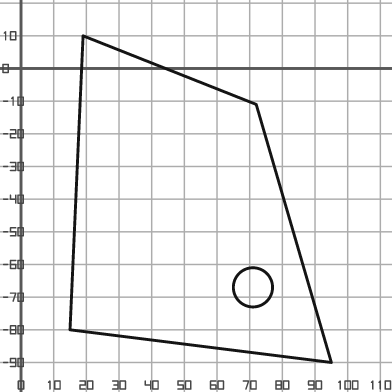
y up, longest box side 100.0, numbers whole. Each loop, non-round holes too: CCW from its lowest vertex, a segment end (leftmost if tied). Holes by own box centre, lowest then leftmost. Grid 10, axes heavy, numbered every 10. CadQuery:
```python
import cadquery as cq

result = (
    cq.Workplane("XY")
    .moveTo(95.0, -90.0)
    .lineTo(72.0, -11.0)
    .lineTo(19.0, 10.0)
    .lineTo(15.0, -80.0)
    .close()
    .moveTo(71.0, -67.0)
    .circle(6.0)
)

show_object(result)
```